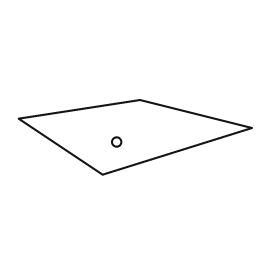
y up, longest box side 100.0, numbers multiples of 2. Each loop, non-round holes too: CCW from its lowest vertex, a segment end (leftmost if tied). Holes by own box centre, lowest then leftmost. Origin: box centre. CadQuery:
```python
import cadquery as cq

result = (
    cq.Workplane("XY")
    .moveTo(-14.0, -16.0)
    .lineTo(50.0, 4.0)
    .lineTo(2.0, 16.0)
    .lineTo(-50.0, 8.0)
    .close()
    .moveTo(-8.0, -2.0)
    .circle(2.0)
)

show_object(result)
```